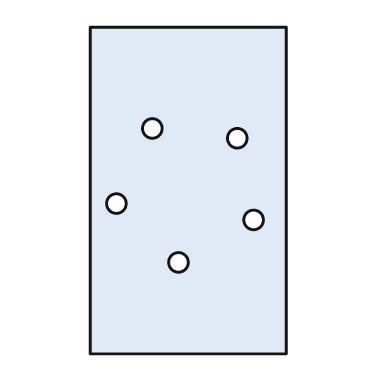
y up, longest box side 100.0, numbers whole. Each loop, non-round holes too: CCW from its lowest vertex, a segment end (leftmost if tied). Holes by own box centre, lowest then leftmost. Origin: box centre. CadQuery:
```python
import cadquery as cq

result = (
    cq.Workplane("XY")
    .moveTo(-30.0, -50.0)
    .lineTo(30.0, -50.0)
    .lineTo(30.0, 50.0)
    .lineTo(-30.0, 50.0)
    .close()
    .moveTo(-3.0, -22.0)
    .circle(3.0)
    .moveTo(20.0, -9.0)
    .circle(3.0)
    .moveTo(-22.0, -4.0)
    .circle(3.0)
    .moveTo(15.0, 16.0)
    .circle(3.0)
    .moveTo(-11.0, 19.0)
    .circle(3.0)
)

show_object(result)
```